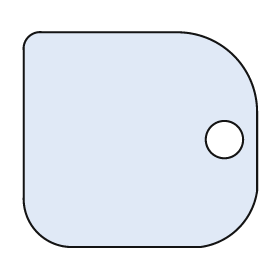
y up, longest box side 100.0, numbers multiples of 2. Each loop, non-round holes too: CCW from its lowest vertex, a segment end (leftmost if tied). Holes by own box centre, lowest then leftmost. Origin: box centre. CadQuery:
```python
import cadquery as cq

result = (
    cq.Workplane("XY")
    .moveTo(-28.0, -46.0)
    .lineTo(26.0, -46.0)
    .threePointArc((42.0, -38.0), (50.0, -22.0))
    .lineTo(50.0, 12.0)
    .threePointArc((40.0, 36.0), (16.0, 46.0))
    .lineTo(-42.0, 46.0)
    .threePointArc((-48.0, 44.0), (-50.0, 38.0))
    .lineTo(-50.0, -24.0)
    .threePointArc((-44.0, -40.0), (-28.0, -46.0))
    .close()
    .moveTo(36.0, 0.0)
    .circle(8.0)
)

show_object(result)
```